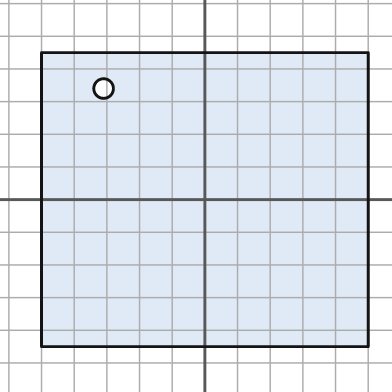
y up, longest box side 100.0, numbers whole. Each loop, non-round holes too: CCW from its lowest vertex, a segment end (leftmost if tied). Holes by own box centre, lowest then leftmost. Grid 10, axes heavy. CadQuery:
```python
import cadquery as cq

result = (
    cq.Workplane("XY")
    .moveTo(-50.0, -45.0)
    .lineTo(50.0, -45.0)
    .lineTo(50.0, 45.0)
    .lineTo(-50.0, 45.0)
    .close()
    .moveTo(-31.0, 34.0)
    .circle(3.0)
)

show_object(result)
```